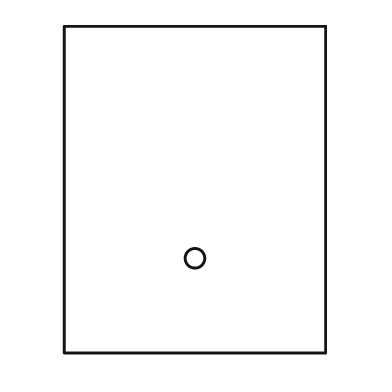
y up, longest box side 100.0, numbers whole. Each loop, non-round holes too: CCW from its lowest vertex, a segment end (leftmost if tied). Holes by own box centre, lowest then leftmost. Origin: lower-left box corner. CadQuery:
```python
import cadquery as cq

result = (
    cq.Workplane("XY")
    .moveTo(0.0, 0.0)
    .lineTo(80.0, 0.0)
    .lineTo(80.0, 100.0)
    .lineTo(0.0, 100.0)
    .close()
    .moveTo(40.0, 29.0)
    .circle(3.0)
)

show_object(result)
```